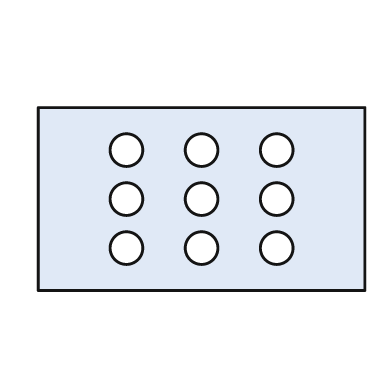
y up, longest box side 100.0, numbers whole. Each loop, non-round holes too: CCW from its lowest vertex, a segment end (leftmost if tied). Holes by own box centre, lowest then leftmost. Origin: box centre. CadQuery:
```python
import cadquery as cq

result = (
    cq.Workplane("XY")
    .moveTo(-50.0, -28.0)
    .lineTo(50.0, -28.0)
    .lineTo(50.0, 28.0)
    .lineTo(-50.0, 28.0)
    .close()
    .moveTo(-23.0, -15.0)
    .circle(5.0)
    .moveTo(0.0, -15.0)
    .circle(5.0)
    .moveTo(23.0, -15.0)
    .circle(5.0)
    .moveTo(-23.0, 0.0)
    .circle(5.0)
    .moveTo(0.0, 0.0)
    .circle(5.0)
    .moveTo(23.0, 0.0)
    .circle(5.0)
    .moveTo(-23.0, 15.0)
    .circle(5.0)
    .moveTo(0.0, 15.0)
    .circle(5.0)
    .moveTo(23.0, 15.0)
    .circle(5.0)
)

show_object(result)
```